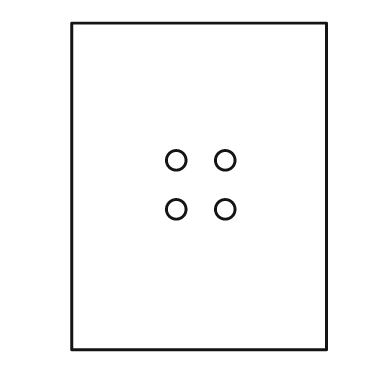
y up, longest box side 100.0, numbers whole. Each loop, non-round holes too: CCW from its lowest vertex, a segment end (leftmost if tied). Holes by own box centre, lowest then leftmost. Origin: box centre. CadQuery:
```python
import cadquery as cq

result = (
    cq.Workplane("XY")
    .moveTo(-39.0, -50.0)
    .lineTo(39.0, -50.0)
    .lineTo(39.0, 50.0)
    .lineTo(-39.0, 50.0)
    .close()
    .moveTo(-7.0, -7.0)
    .circle(3.0)
    .moveTo(8.0, -7.0)
    .circle(3.0)
    .moveTo(-7.0, 8.0)
    .circle(3.0)
    .moveTo(8.0, 8.0)
    .circle(3.0)
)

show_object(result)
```